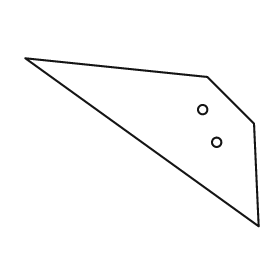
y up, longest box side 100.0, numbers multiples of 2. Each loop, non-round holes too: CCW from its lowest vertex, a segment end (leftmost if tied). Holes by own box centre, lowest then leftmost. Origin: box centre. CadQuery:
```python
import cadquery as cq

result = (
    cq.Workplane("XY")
    .moveTo(50.0, -36.0)
    .lineTo(48.0, 8.0)
    .lineTo(28.0, 28.0)
    .lineTo(-50.0, 36.0)
    .close()
    .moveTo(32.0, 0.0)
    .circle(2.0)
    .moveTo(26.0, 14.0)
    .circle(2.0)
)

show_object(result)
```